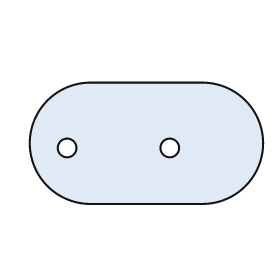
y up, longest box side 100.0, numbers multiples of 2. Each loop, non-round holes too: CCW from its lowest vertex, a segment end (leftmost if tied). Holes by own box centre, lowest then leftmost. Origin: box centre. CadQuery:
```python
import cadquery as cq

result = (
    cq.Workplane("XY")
    .moveTo(-24.0, -26.0)
    .lineTo(24.0, -26.0)
    .threePointArc((50.0, 0.0), (24.0, 26.0))
    .lineTo(-24.0, 26.0)
    .threePointArc((-50.0, 0.0), (-24.0, -26.0))
    .close()
    .moveTo(-34.0, -2.0)
    .circle(4.0)
    .moveTo(10.0, -2.0)
    .circle(4.0)
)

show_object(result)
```